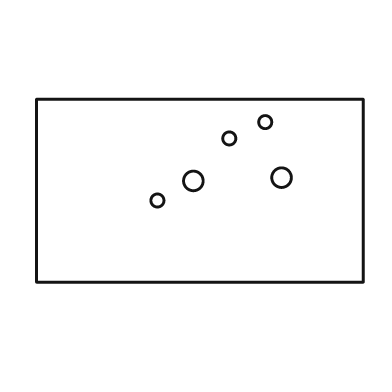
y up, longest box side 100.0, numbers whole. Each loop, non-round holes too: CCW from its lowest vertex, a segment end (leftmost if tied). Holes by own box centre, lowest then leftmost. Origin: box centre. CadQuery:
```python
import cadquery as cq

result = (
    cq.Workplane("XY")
    .moveTo(-50.0, -28.0)
    .lineTo(50.0, -28.0)
    .lineTo(50.0, 28.0)
    .lineTo(-50.0, 28.0)
    .close()
    .moveTo(-13.0, -3.0)
    .circle(2.0)
    .moveTo(-2.0, 3.0)
    .circle(3.0)
    .moveTo(25.0, 4.0)
    .circle(3.0)
    .moveTo(9.0, 16.0)
    .circle(2.0)
    .moveTo(20.0, 21.0)
    .circle(2.0)
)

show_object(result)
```